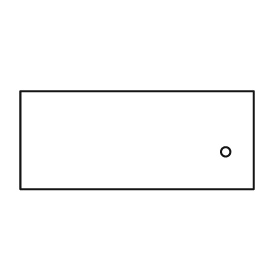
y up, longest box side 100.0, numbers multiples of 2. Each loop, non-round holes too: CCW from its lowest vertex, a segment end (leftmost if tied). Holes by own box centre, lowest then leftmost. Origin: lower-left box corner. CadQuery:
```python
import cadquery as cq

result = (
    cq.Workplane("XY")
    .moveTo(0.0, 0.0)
    .lineTo(100.0, 0.0)
    .lineTo(100.0, 42.0)
    .lineTo(0.0, 42.0)
    .close()
    .moveTo(88.0, 16.0)
    .circle(2.0)
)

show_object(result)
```